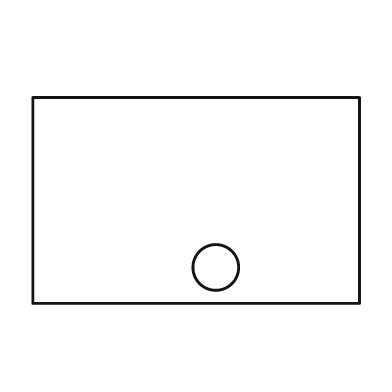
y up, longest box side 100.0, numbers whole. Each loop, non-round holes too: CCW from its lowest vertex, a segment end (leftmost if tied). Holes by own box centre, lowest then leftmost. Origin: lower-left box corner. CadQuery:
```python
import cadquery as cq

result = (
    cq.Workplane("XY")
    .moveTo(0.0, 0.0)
    .lineTo(100.0, 0.0)
    .lineTo(100.0, 63.0)
    .lineTo(0.0, 63.0)
    .close()
    .moveTo(56.0, 11.0)
    .circle(7.0)
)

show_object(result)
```